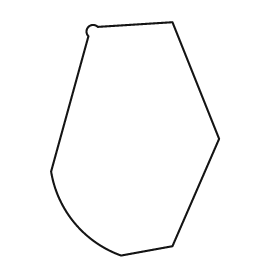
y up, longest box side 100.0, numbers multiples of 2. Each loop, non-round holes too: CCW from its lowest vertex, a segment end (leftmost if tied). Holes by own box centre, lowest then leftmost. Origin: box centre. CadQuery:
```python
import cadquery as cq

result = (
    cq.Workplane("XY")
    .moveTo(-6.0, -50.0)
    .lineTo(16.0, -46.0)
    .lineTo(36.0, 0.0)
    .lineTo(16.0, 50.0)
    .lineTo(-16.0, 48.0)
    .threePointArc((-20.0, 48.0), (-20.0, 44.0))
    .lineTo(-36.0, -14.0)
    .threePointArc((-26.0, -36.0), (-6.0, -50.0))
    .close()
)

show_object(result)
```